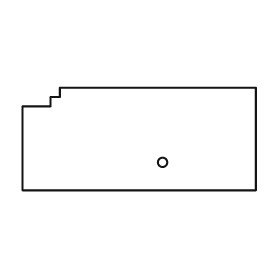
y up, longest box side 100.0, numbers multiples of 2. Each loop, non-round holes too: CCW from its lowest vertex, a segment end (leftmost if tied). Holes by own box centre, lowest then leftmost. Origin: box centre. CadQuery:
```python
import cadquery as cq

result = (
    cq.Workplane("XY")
    .moveTo(-50.0, -22.0)
    .lineTo(50.0, -22.0)
    .lineTo(50.0, 22.0)
    .lineTo(-34.0, 22.0)
    .lineTo(-34.0, 18.0)
    .lineTo(-38.0, 18.0)
    .lineTo(-38.0, 14.0)
    .lineTo(-50.0, 14.0)
    .close()
    .moveTo(10.0, -10.0)
    .circle(2.0)
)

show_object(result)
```